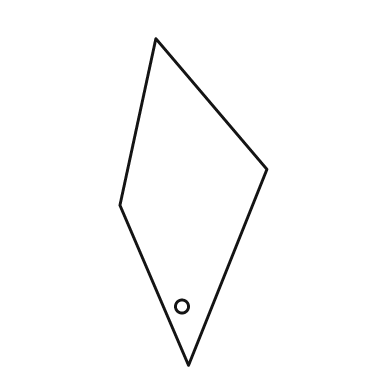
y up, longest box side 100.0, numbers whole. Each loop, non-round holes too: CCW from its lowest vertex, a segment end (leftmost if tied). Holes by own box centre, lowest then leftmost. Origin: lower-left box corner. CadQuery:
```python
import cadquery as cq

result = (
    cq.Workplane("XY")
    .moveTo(21.0, 0.0)
    .lineTo(45.0, 60.0)
    .lineTo(11.0, 100.0)
    .lineTo(0.0, 49.0)
    .close()
    .moveTo(19.0, 18.0)
    .circle(2.0)
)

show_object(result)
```